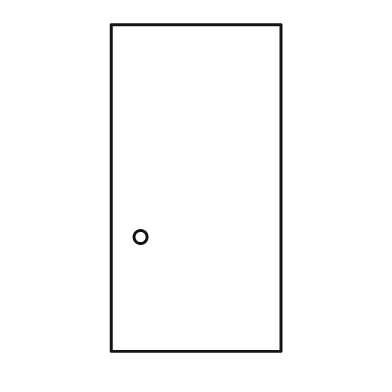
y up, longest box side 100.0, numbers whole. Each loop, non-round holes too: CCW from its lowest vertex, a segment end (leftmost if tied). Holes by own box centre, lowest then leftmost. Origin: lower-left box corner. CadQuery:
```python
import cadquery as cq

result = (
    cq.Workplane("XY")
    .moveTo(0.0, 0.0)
    .lineTo(52.0, 0.0)
    .lineTo(52.0, 100.0)
    .lineTo(0.0, 100.0)
    .close()
    .moveTo(9.0, 35.0)
    .circle(2.0)
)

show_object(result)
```